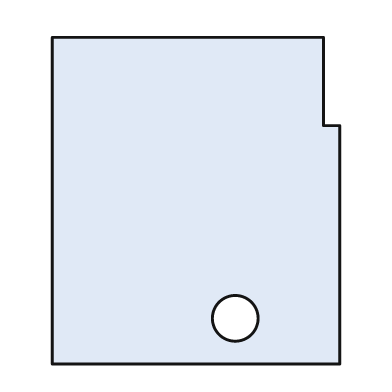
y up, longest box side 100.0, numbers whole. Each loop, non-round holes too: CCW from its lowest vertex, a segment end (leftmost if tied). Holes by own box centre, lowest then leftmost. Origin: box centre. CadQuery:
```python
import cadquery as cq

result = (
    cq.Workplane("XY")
    .moveTo(-44.0, -50.0)
    .lineTo(44.0, -50.0)
    .lineTo(44.0, 23.0)
    .lineTo(39.0, 23.0)
    .lineTo(39.0, 50.0)
    .lineTo(-44.0, 50.0)
    .close()
    .moveTo(12.0, -36.0)
    .circle(7.0)
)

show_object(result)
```